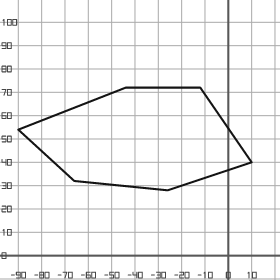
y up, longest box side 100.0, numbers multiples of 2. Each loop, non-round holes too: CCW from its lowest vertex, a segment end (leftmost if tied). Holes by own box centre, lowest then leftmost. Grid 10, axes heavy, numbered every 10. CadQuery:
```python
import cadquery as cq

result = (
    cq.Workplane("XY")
    .moveTo(-26.0, 28.0)
    .lineTo(10.0, 40.0)
    .lineTo(-12.0, 72.0)
    .lineTo(-44.0, 72.0)
    .lineTo(-90.0, 54.0)
    .lineTo(-66.0, 32.0)
    .close()
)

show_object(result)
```